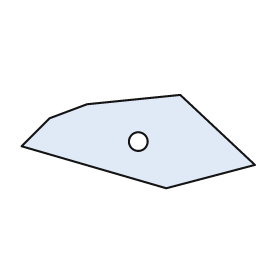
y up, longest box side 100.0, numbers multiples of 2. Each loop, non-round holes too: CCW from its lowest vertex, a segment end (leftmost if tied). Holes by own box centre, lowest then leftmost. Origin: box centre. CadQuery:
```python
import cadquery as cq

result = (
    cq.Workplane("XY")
    .moveTo(12.0, -20.0)
    .lineTo(50.0, -10.0)
    .lineTo(18.0, 20.0)
    .lineTo(-22.0, 16.0)
    .lineTo(-38.0, 10.0)
    .lineTo(-50.0, -2.0)
    .close()
    .moveTo(0.0, 0.0)
    .circle(4.0)
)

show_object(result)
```